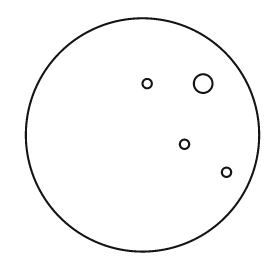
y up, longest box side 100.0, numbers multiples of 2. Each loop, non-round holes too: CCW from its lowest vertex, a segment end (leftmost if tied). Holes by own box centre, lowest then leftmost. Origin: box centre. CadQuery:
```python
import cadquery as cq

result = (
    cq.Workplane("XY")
    .moveTo(0.0, 0.0)
    .circle(50.0)
    .moveTo(36.0, -16.0)
    .circle(2.0)
    .moveTo(18.0, -4.0)
    .circle(2.0)
    .moveTo(2.0, 22.0)
    .circle(2.0)
    .moveTo(26.0, 22.0)
    .circle(4.0)
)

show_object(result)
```